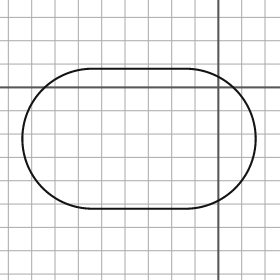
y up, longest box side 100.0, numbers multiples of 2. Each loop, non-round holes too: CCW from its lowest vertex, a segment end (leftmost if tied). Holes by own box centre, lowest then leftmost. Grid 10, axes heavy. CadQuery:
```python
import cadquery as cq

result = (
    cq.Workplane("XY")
    .moveTo(-54.0, -52.0)
    .lineTo(-14.0, -52.0)
    .threePointArc((16.0, -22.0), (-14.0, 8.0))
    .lineTo(-54.0, 8.0)
    .threePointArc((-84.0, -22.0), (-54.0, -52.0))
    .close()
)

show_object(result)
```